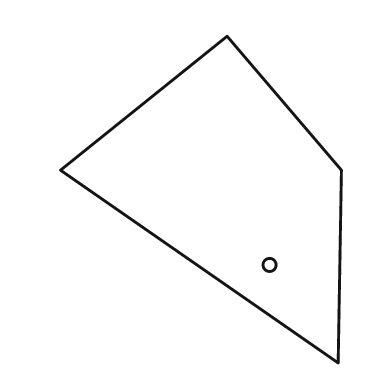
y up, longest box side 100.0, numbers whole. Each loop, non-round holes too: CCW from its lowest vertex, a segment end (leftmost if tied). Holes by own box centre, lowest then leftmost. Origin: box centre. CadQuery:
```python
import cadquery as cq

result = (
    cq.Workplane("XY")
    .moveTo(42.0, -50.0)
    .lineTo(43.0, 9.0)
    .lineTo(8.0, 50.0)
    .lineTo(-43.0, 9.0)
    .close()
    .moveTo(21.0, -20.0)
    .circle(2.0)
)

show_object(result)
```